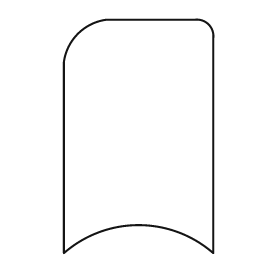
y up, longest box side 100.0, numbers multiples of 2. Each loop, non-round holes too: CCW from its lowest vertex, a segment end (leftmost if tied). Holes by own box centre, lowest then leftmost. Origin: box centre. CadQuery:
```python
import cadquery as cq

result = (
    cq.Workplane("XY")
    .moveTo(-32.0, -50.0)
    .threePointArc((0.0, -38.0), (32.0, -50.0))
    .lineTo(32.0, 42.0)
    .threePointArc((30.0, 48.0), (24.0, 50.0))
    .lineTo(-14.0, 50.0)
    .threePointArc((-26.0, 44.0), (-32.0, 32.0))
    .close()
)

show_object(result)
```